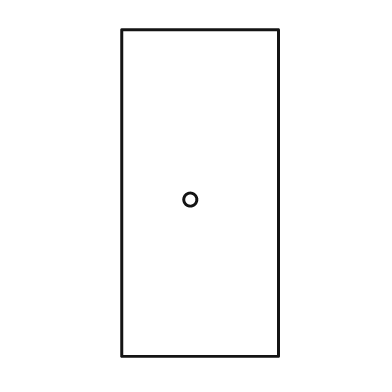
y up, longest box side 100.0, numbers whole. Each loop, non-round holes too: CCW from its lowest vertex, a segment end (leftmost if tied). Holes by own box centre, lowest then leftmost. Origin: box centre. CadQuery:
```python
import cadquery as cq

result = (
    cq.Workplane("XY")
    .moveTo(-24.0, -50.0)
    .lineTo(24.0, -50.0)
    .lineTo(24.0, 50.0)
    .lineTo(-24.0, 50.0)
    .close()
    .moveTo(-3.0, -2.0)
    .circle(2.0)
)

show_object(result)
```